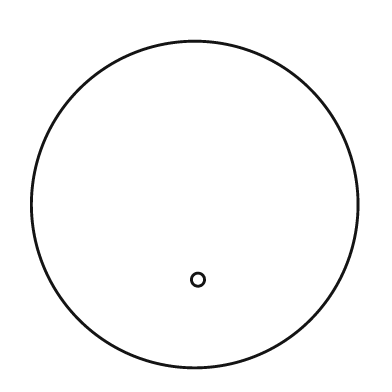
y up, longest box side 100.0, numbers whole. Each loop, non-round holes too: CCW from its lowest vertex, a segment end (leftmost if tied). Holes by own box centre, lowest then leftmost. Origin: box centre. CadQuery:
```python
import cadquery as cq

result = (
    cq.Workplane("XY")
    .moveTo(0.0, 0.0)
    .circle(50.0)
    .moveTo(1.0, -23.0)
    .circle(2.0)
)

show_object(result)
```